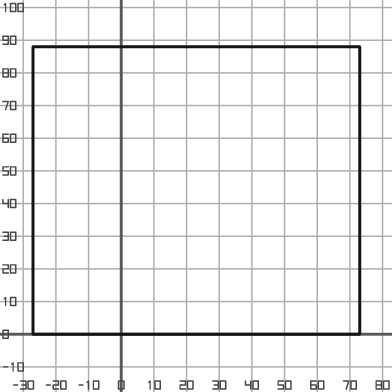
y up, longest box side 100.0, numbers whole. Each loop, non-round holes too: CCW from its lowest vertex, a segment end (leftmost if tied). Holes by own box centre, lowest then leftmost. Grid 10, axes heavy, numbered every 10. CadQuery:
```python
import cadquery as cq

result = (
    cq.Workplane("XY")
    .moveTo(-27.0, 0.0)
    .lineTo(73.0, 0.0)
    .lineTo(73.0, 88.0)
    .lineTo(-27.0, 88.0)
    .close()
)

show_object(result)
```